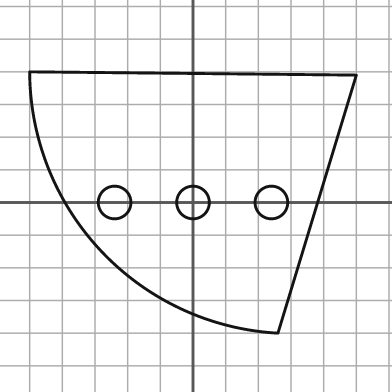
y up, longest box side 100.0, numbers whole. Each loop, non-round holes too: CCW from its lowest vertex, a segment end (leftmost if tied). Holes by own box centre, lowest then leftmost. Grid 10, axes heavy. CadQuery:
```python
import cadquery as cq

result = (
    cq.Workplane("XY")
    .moveTo(26.0, -40.0)
    .lineTo(50.0, 39.0)
    .lineTo(-50.0, 40.0)
    .threePointArc((-28.0, -15.0), (26.0, -40.0))
    .close()
    .moveTo(-24.0, 0.0)
    .circle(5.0)
    .moveTo(0.0, 0.0)
    .circle(5.0)
    .moveTo(24.0, 0.0)
    .circle(5.0)
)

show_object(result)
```